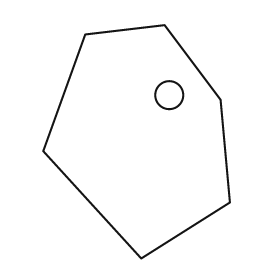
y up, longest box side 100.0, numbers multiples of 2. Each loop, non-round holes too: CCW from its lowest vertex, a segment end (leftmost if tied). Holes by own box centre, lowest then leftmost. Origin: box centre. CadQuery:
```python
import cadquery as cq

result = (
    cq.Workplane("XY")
    .moveTo(2.0, -50.0)
    .lineTo(40.0, -26.0)
    .lineTo(36.0, 18.0)
    .lineTo(12.0, 50.0)
    .lineTo(-22.0, 46.0)
    .lineTo(-40.0, -4.0)
    .close()
    .moveTo(14.0, 20.0)
    .circle(6.0)
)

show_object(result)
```